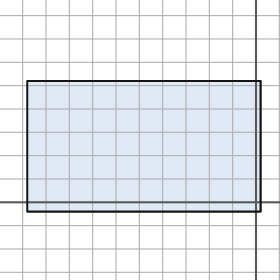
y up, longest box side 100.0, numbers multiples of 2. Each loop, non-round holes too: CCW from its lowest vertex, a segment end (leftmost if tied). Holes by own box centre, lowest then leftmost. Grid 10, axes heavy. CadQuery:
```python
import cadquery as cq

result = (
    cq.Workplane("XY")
    .moveTo(-98.0, -4.0)
    .lineTo(2.0, -4.0)
    .lineTo(2.0, 52.0)
    .lineTo(-98.0, 52.0)
    .close()
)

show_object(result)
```